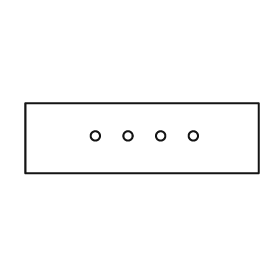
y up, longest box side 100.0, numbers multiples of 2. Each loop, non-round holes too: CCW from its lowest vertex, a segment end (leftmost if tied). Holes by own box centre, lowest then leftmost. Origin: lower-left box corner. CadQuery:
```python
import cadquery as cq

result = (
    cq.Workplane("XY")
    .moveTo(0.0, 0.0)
    .lineTo(100.0, 0.0)
    .lineTo(100.0, 30.0)
    .lineTo(0.0, 30.0)
    .close()
    .moveTo(30.0, 16.0)
    .circle(2.0)
    .moveTo(44.0, 16.0)
    .circle(2.0)
    .moveTo(58.0, 16.0)
    .circle(2.0)
    .moveTo(72.0, 16.0)
    .circle(2.0)
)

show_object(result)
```